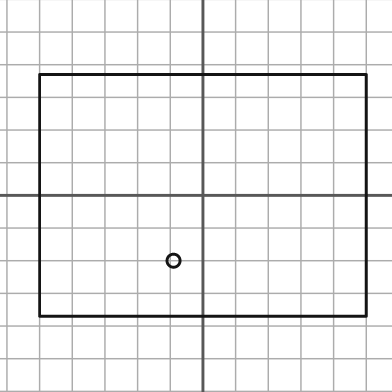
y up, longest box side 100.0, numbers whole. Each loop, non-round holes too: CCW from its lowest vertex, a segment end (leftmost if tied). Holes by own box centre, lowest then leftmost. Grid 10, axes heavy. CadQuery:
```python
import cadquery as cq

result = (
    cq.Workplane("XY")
    .moveTo(-50.0, -37.0)
    .lineTo(50.0, -37.0)
    .lineTo(50.0, 37.0)
    .lineTo(-50.0, 37.0)
    .close()
    .moveTo(-9.0, -20.0)
    .circle(2.0)
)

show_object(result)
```